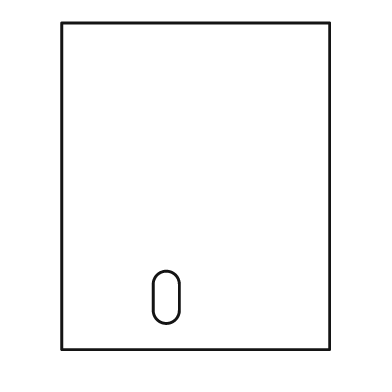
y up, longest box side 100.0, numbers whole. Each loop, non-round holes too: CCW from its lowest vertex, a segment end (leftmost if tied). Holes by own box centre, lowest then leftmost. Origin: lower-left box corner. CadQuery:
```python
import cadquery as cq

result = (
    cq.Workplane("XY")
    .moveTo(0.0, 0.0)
    .lineTo(82.0, 0.0)
    .lineTo(82.0, 100.0)
    .lineTo(0.0, 100.0)
    .close()
    .moveTo(28.0, 12.0)
    .threePointArc((32.0, 8.0), (36.0, 12.0))
    .lineTo(36.0, 20.0)
    .threePointArc((32.0, 24.0), (28.0, 20.0))
    .close()
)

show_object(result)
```